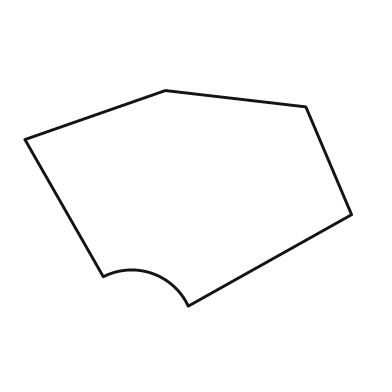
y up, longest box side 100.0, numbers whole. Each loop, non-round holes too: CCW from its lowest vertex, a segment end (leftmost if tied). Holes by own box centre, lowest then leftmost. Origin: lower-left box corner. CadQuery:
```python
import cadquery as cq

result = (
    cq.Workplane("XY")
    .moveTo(50.0, 0.0)
    .lineTo(100.0, 28.0)
    .lineTo(86.0, 61.0)
    .lineTo(43.0, 66.0)
    .lineTo(0.0, 51.0)
    .lineTo(24.0, 9.0)
    .threePointArc((39.0, 10.0), (50.0, 0.0))
    .close()
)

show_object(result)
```